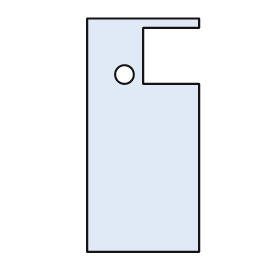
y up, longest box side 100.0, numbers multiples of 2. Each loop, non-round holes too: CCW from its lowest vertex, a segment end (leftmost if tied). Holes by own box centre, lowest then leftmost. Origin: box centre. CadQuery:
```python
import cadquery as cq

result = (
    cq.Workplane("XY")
    .moveTo(-24.0, -50.0)
    .lineTo(24.0, -50.0)
    .lineTo(24.0, 22.0)
    .lineTo(0.0, 22.0)
    .lineTo(0.0, 46.0)
    .lineTo(24.0, 46.0)
    .lineTo(24.0, 50.0)
    .lineTo(-24.0, 50.0)
    .close()
    .moveTo(-8.0, 26.0)
    .circle(4.0)
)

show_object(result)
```